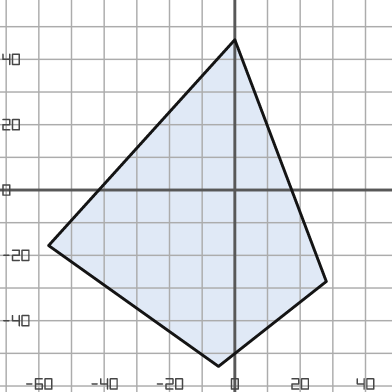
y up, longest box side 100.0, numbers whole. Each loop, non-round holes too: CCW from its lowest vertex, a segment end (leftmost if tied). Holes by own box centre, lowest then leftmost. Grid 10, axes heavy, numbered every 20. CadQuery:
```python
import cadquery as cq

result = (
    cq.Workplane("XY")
    .moveTo(-5.0, -54.0)
    .lineTo(28.0, -28.0)
    .lineTo(0.0, 46.0)
    .lineTo(-57.0, -17.0)
    .close()
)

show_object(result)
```